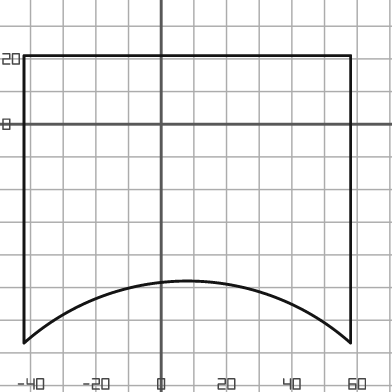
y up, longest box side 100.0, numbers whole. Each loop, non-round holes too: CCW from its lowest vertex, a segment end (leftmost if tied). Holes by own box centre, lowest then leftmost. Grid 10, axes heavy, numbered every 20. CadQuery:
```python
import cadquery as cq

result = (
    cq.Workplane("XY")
    .moveTo(-42.0, -67.0)
    .threePointArc((8.0, -48.0), (58.0, -67.0))
    .lineTo(58.0, 21.0)
    .lineTo(-42.0, 21.0)
    .close()
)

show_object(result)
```